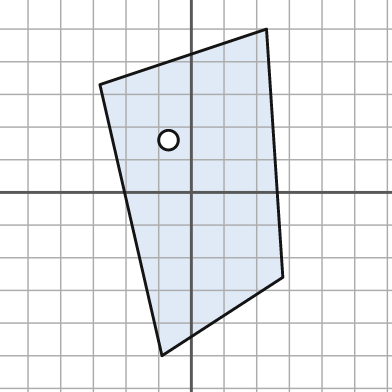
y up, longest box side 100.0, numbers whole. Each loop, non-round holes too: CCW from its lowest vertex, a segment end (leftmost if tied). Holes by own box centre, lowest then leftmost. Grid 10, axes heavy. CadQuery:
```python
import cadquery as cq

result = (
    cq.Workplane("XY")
    .moveTo(-9.0, -50.0)
    .lineTo(28.0, -26.0)
    .lineTo(23.0, 50.0)
    .lineTo(-28.0, 33.0)
    .close()
    .moveTo(-7.0, 16.0)
    .circle(3.0)
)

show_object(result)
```